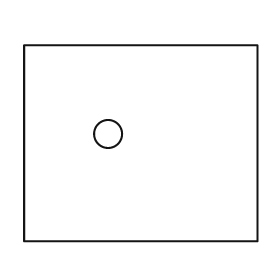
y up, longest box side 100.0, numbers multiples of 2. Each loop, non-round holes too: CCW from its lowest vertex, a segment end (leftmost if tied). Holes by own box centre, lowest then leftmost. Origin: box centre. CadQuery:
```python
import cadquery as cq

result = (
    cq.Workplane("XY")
    .moveTo(-50.0, -42.0)
    .lineTo(50.0, -42.0)
    .lineTo(50.0, 42.0)
    .lineTo(-50.0, 42.0)
    .close()
    .moveTo(-14.0, 4.0)
    .circle(6.0)
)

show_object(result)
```